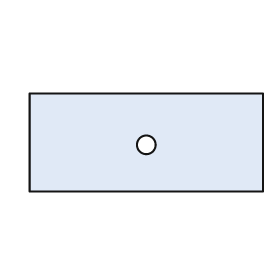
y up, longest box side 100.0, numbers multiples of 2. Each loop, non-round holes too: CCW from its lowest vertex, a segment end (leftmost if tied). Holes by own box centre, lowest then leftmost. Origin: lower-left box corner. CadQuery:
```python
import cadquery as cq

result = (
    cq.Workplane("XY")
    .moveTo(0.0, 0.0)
    .lineTo(100.0, 0.0)
    .lineTo(100.0, 42.0)
    .lineTo(0.0, 42.0)
    .close()
    .moveTo(50.0, 20.0)
    .circle(4.0)
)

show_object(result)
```